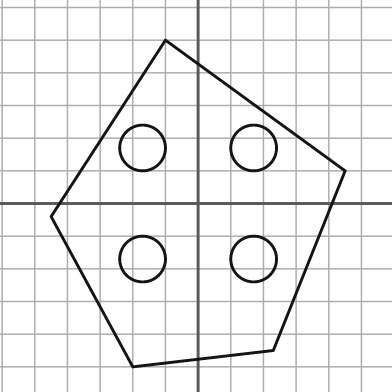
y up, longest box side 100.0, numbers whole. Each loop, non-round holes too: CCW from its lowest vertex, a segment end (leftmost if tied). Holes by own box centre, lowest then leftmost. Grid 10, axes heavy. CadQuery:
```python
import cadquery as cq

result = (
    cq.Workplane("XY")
    .moveTo(-20.0, -50.0)
    .lineTo(23.0, -45.0)
    .lineTo(45.0, 10.0)
    .lineTo(-10.0, 50.0)
    .lineTo(-45.0, -4.0)
    .close()
    .moveTo(-17.0, -17.0)
    .circle(7.0)
    .moveTo(17.0, -17.0)
    .circle(7.0)
    .moveTo(-17.0, 17.0)
    .circle(7.0)
    .moveTo(17.0, 17.0)
    .circle(7.0)
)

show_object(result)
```